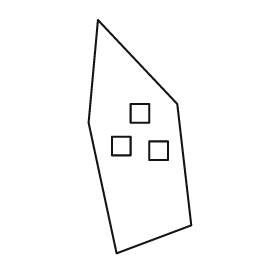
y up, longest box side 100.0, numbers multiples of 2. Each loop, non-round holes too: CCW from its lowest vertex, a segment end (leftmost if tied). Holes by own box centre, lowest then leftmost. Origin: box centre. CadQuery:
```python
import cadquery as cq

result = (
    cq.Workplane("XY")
    .moveTo(-10.0, -50.0)
    .lineTo(22.0, -38.0)
    .lineTo(16.0, 14.0)
    .lineTo(-18.0, 50.0)
    .lineTo(-22.0, 6.0)
    .close()
    .moveTo(4.0, -10.0)
    .lineTo(12.0, -10.0)
    .lineTo(12.0, -2.0)
    .lineTo(4.0, -2.0)
    .close()
    .moveTo(-12.0, -8.0)
    .lineTo(-4.0, -8.0)
    .lineTo(-4.0, 0.0)
    .lineTo(-12.0, 0.0)
    .close()
    .moveTo(-4.0, 6.0)
    .lineTo(4.0, 6.0)
    .lineTo(4.0, 14.0)
    .lineTo(-4.0, 14.0)
    .close()
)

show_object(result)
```